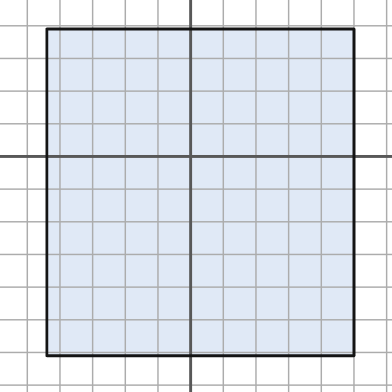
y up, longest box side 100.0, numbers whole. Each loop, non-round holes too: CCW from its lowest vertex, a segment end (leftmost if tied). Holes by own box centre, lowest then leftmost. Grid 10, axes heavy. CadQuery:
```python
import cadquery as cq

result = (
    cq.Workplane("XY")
    .moveTo(-44.0, -61.0)
    .lineTo(50.0, -61.0)
    .lineTo(50.0, 39.0)
    .lineTo(-44.0, 39.0)
    .close()
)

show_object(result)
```